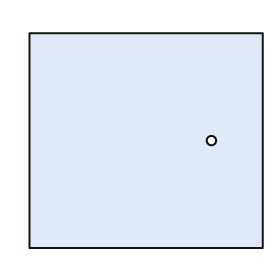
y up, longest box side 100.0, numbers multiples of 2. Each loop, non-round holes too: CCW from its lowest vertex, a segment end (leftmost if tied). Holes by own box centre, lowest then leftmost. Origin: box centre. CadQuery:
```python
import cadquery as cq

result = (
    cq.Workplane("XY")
    .moveTo(-50.0, -46.0)
    .lineTo(50.0, -46.0)
    .lineTo(50.0, 46.0)
    .lineTo(-50.0, 46.0)
    .close()
    .moveTo(28.0, 0.0)
    .circle(2.0)
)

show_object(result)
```